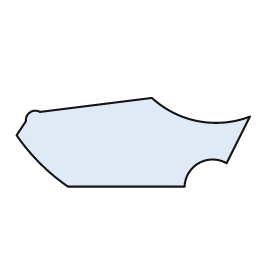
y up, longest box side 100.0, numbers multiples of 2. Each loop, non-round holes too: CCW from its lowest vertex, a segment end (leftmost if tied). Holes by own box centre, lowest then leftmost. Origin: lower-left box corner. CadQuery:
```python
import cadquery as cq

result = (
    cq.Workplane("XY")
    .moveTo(22.0, 0.0)
    .lineTo(72.0, 0.0)
    .threePointArc((78.0, 10.0), (90.0, 10.0))
    .lineTo(100.0, 30.0)
    .threePointArc((78.0, 28.0), (58.0, 38.0))
    .lineTo(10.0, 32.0)
    .threePointArc((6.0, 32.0), (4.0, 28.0))
    .lineTo(0.0, 22.0)
    .threePointArc((10.0, 10.0), (22.0, 0.0))
    .close()
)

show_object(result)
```